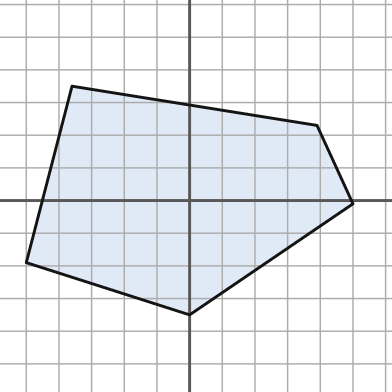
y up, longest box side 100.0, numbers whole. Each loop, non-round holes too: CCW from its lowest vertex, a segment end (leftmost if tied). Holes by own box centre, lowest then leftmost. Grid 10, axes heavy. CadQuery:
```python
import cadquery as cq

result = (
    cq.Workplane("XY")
    .moveTo(0.0, -35.0)
    .lineTo(50.0, -1.0)
    .lineTo(39.0, 23.0)
    .lineTo(-36.0, 35.0)
    .lineTo(-50.0, -19.0)
    .close()
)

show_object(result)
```